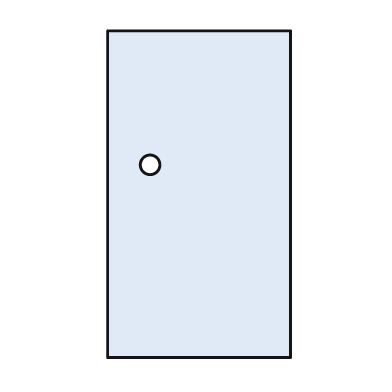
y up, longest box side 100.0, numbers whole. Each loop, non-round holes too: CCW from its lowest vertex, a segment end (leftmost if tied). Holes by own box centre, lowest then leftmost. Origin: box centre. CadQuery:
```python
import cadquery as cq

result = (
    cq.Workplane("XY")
    .moveTo(-28.0, -50.0)
    .lineTo(28.0, -50.0)
    .lineTo(28.0, 50.0)
    .lineTo(-28.0, 50.0)
    .close()
    .moveTo(-15.0, 9.0)
    .circle(3.0)
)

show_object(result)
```